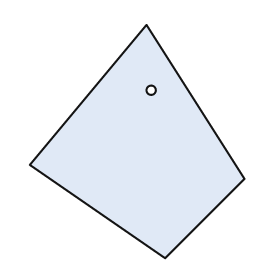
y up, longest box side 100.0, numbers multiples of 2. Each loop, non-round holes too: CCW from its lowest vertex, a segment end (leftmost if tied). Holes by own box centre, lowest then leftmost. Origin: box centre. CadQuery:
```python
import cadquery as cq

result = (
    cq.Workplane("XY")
    .moveTo(12.0, -50.0)
    .lineTo(46.0, -16.0)
    .lineTo(4.0, 50.0)
    .lineTo(-46.0, -10.0)
    .close()
    .moveTo(6.0, 22.0)
    .circle(2.0)
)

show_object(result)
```